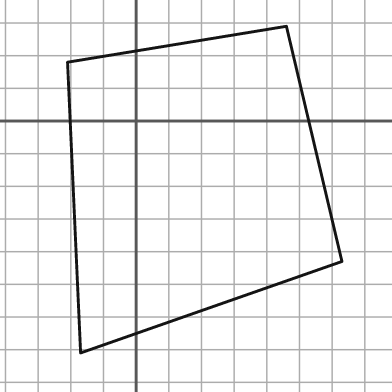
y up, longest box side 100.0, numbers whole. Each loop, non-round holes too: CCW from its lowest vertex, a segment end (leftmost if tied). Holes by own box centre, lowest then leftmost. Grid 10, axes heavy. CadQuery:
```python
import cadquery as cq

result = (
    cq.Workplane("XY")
    .moveTo(-17.0, -71.0)
    .lineTo(63.0, -43.0)
    .lineTo(46.0, 29.0)
    .lineTo(-21.0, 18.0)
    .close()
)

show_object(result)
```